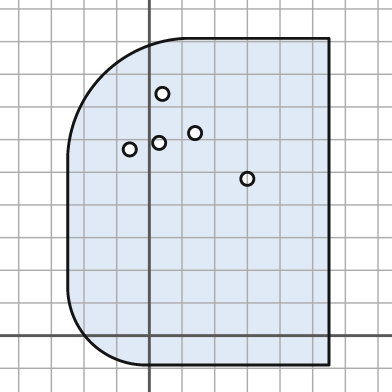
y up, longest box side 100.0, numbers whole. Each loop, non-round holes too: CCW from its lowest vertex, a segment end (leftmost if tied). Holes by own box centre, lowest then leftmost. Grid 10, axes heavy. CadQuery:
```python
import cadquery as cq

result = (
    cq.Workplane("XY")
    .moveTo(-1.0, -9.0)
    .lineTo(55.0, -9.0)
    .lineTo(55.0, 91.0)
    .lineTo(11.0, 91.0)
    .threePointArc((-14.0, 80.0), (-25.0, 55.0))
    .lineTo(-25.0, 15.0)
    .threePointArc((-18.0, -2.0), (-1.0, -9.0))
    .close()
    .moveTo(30.0, 48.0)
    .circle(2.0)
    .moveTo(-6.0, 57.0)
    .circle(2.0)
    .moveTo(3.0, 59.0)
    .circle(2.0)
    .moveTo(14.0, 62.0)
    .circle(2.0)
    .moveTo(4.0, 74.0)
    .circle(2.0)
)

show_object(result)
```